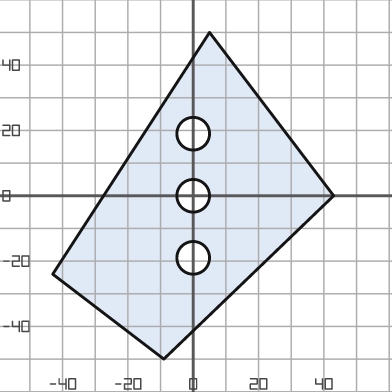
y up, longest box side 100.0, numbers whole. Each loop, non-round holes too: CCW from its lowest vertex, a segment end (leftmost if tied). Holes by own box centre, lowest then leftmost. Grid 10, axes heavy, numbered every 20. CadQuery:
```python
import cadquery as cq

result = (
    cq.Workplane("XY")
    .moveTo(-9.0, -50.0)
    .lineTo(43.0, 0.0)
    .lineTo(5.0, 50.0)
    .lineTo(-43.0, -24.0)
    .close()
    .moveTo(0.0, -19.0)
    .circle(5.0)
    .moveTo(0.0, 0.0)
    .circle(5.0)
    .moveTo(0.0, 19.0)
    .circle(5.0)
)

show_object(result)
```